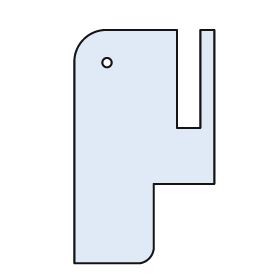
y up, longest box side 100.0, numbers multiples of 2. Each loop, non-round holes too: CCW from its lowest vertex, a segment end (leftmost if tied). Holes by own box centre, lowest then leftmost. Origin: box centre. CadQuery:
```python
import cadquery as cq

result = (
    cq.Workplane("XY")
    .moveTo(-30.0, -50.0)
    .lineTo(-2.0, -50.0)
    .threePointArc((2.0, -48.0), (4.0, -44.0))
    .lineTo(4.0, -16.0)
    .lineTo(30.0, -16.0)
    .lineTo(30.0, 50.0)
    .lineTo(24.0, 50.0)
    .lineTo(24.0, 8.0)
    .lineTo(14.0, 8.0)
    .lineTo(14.0, 50.0)
    .lineTo(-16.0, 50.0)
    .threePointArc((-26.0, 46.0), (-30.0, 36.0))
    .close()
    .moveTo(-16.0, 36.0)
    .circle(2.0)
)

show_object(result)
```